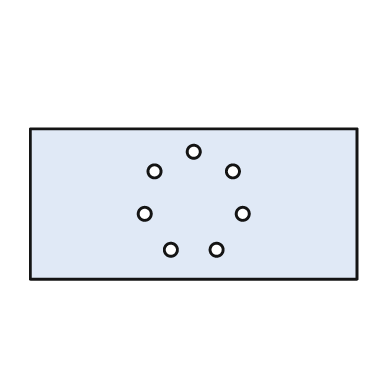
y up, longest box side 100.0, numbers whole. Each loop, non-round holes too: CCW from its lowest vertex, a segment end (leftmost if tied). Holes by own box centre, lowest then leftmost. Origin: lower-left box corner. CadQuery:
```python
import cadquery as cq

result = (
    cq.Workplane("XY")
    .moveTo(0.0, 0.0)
    .lineTo(100.0, 0.0)
    .lineTo(100.0, 46.0)
    .lineTo(0.0, 46.0)
    .close()
    .moveTo(43.0, 9.0)
    .circle(2.0)
    .moveTo(57.0, 9.0)
    .circle(2.0)
    .moveTo(35.0, 20.0)
    .circle(2.0)
    .moveTo(65.0, 20.0)
    .circle(2.0)
    .moveTo(38.0, 33.0)
    .circle(2.0)
    .moveTo(62.0, 33.0)
    .circle(2.0)
    .moveTo(50.0, 39.0)
    .circle(2.0)
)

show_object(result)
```